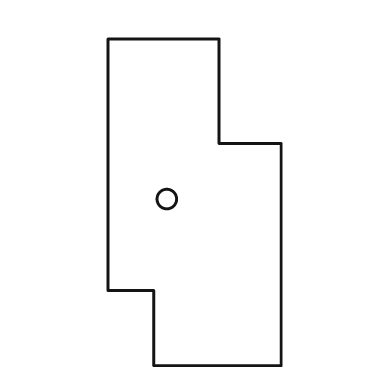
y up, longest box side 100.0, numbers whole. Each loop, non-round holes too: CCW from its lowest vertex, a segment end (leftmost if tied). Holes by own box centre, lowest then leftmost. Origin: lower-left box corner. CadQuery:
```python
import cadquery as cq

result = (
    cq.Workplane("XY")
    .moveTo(14.0, 0.0)
    .lineTo(53.0, 0.0)
    .lineTo(53.0, 68.0)
    .lineTo(34.0, 68.0)
    .lineTo(34.0, 100.0)
    .lineTo(0.0, 100.0)
    .lineTo(0.0, 23.0)
    .lineTo(14.0, 23.0)
    .close()
    .moveTo(18.0, 51.0)
    .circle(3.0)
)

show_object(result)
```